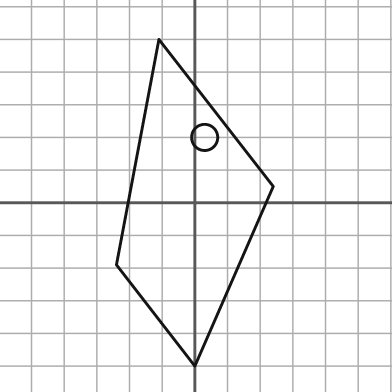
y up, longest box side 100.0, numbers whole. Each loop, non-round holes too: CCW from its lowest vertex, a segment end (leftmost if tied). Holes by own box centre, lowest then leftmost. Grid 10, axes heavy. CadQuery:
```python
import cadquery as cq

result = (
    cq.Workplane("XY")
    .moveTo(0.0, -50.0)
    .lineTo(24.0, 5.0)
    .lineTo(-11.0, 50.0)
    .lineTo(-24.0, -19.0)
    .close()
    .moveTo(3.0, 20.0)
    .circle(4.0)
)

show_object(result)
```